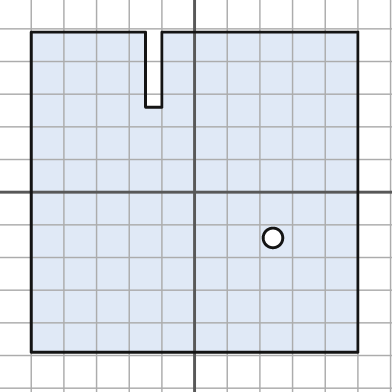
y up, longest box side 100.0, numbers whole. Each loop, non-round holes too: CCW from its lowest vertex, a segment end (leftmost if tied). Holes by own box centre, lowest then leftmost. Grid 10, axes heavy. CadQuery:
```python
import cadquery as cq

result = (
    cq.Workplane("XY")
    .moveTo(-50.0, -49.0)
    .lineTo(50.0, -49.0)
    .lineTo(50.0, 49.0)
    .lineTo(-10.0, 49.0)
    .lineTo(-10.0, 26.0)
    .lineTo(-15.0, 26.0)
    .lineTo(-15.0, 49.0)
    .lineTo(-50.0, 49.0)
    .close()
    .moveTo(24.0, -14.0)
    .circle(3.0)
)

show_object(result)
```